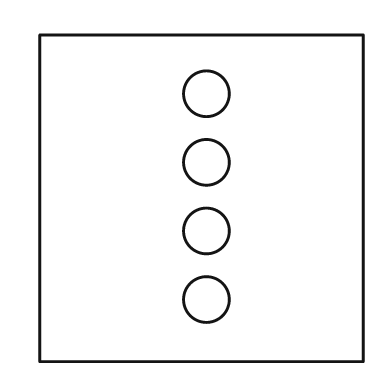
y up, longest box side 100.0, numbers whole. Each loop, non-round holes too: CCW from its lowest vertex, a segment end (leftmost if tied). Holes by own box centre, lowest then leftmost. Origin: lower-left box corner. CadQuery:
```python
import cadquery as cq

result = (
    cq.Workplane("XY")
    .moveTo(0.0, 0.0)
    .lineTo(99.0, 0.0)
    .lineTo(99.0, 100.0)
    .lineTo(0.0, 100.0)
    .close()
    .moveTo(51.0, 19.0)
    .circle(7.0)
    .moveTo(51.0, 40.0)
    .circle(7.0)
    .moveTo(51.0, 61.0)
    .circle(7.0)
    .moveTo(51.0, 82.0)
    .circle(7.0)
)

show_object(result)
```